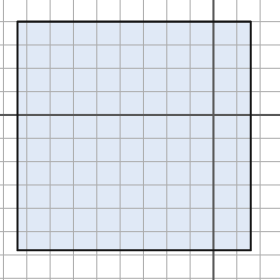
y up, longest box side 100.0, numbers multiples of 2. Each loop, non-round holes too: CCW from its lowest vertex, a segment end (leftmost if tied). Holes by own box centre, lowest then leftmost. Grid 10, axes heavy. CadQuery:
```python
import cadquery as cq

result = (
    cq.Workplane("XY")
    .moveTo(-84.0, -58.0)
    .lineTo(16.0, -58.0)
    .lineTo(16.0, 40.0)
    .lineTo(-84.0, 40.0)
    .close()
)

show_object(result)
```